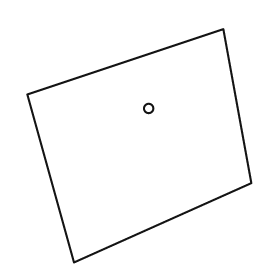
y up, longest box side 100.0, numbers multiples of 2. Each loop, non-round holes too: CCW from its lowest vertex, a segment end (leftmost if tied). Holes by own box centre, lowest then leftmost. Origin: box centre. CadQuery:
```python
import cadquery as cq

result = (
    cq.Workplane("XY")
    .moveTo(-28.0, -50.0)
    .lineTo(48.0, -16.0)
    .lineTo(36.0, 50.0)
    .lineTo(-48.0, 22.0)
    .close()
    .moveTo(4.0, 16.0)
    .circle(2.0)
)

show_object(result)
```